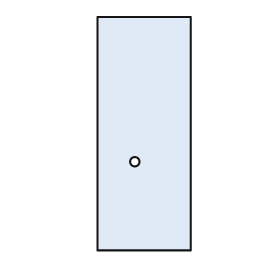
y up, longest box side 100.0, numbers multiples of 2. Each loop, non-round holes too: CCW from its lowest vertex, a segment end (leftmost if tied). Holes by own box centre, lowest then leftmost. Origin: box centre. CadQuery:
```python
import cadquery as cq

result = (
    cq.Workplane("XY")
    .moveTo(-20.0, -50.0)
    .lineTo(20.0, -50.0)
    .lineTo(20.0, 50.0)
    .lineTo(-20.0, 50.0)
    .close()
    .moveTo(-4.0, -12.0)
    .circle(2.0)
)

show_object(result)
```